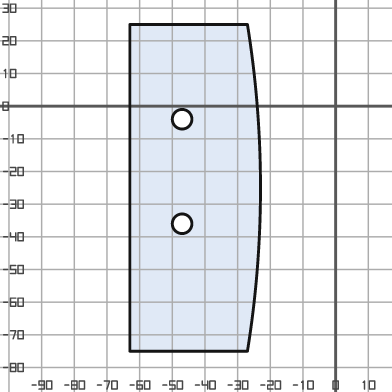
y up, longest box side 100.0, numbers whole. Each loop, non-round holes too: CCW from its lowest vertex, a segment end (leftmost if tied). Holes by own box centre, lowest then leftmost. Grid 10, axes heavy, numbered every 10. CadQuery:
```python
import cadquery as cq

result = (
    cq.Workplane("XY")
    .moveTo(-63.0, -75.0)
    .lineTo(-27.0, -75.0)
    .threePointArc((-23.0, -25.0), (-27.0, 25.0))
    .lineTo(-63.0, 25.0)
    .close()
    .moveTo(-47.0, -36.0)
    .circle(3.0)
    .moveTo(-47.0, -4.0)
    .circle(3.0)
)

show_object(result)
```